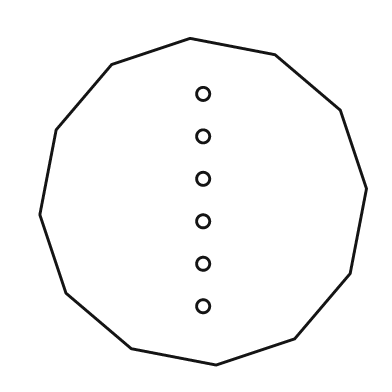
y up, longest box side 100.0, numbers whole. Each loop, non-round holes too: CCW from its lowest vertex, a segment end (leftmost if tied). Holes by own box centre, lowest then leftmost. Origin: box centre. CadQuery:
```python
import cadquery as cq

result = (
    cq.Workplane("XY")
    .moveTo(4.0, -50.0)
    .lineTo(28.0, -42.0)
    .lineTo(45.0, -22.0)
    .lineTo(50.0, 4.0)
    .lineTo(42.0, 28.0)
    .lineTo(22.0, 45.0)
    .lineTo(-4.0, 50.0)
    .lineTo(-28.0, 42.0)
    .lineTo(-45.0, 22.0)
    .lineTo(-50.0, -4.0)
    .lineTo(-42.0, -28.0)
    .lineTo(-22.0, -45.0)
    .close()
    .moveTo(0.0, -32.0)
    .circle(2.0)
    .moveTo(0.0, -19.0)
    .circle(2.0)
    .moveTo(0.0, -6.0)
    .circle(2.0)
    .moveTo(0.0, 7.0)
    .circle(2.0)
    .moveTo(0.0, 20.0)
    .circle(2.0)
    .moveTo(0.0, 33.0)
    .circle(2.0)
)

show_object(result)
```